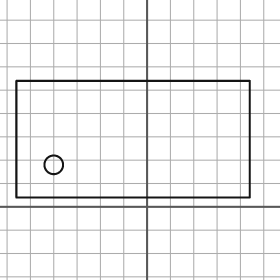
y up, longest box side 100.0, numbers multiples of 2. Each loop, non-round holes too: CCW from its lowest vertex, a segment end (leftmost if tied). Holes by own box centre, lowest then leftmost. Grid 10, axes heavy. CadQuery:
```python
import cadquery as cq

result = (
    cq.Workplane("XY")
    .moveTo(-56.0, 4.0)
    .lineTo(44.0, 4.0)
    .lineTo(44.0, 54.0)
    .lineTo(-56.0, 54.0)
    .close()
    .moveTo(-40.0, 18.0)
    .circle(4.0)
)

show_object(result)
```